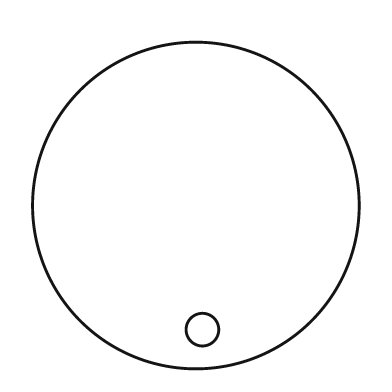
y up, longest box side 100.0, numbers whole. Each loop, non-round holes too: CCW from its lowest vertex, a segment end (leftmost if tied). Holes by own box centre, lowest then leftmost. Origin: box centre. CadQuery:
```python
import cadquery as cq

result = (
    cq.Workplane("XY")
    .moveTo(0.0, 0.0)
    .circle(50.0)
    .moveTo(2.0, -38.0)
    .circle(5.0)
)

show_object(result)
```